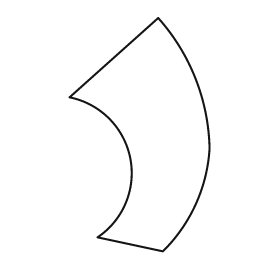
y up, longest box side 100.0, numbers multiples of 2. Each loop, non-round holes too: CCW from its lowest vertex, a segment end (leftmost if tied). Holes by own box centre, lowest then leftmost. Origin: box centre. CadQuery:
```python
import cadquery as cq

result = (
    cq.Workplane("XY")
    .moveTo(10.0, -50.0)
    .threePointArc((24.0, -30.0), (30.0, -6.0))
    .threePointArc((24.0, 24.0), (8.0, 50.0))
    .lineTo(-30.0, 16.0)
    .threePointArc((-4.0, -10.0), (-18.0, -44.0))
    .close()
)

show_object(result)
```